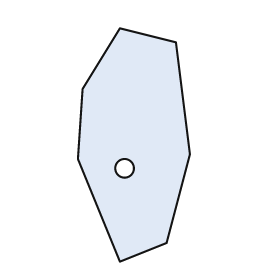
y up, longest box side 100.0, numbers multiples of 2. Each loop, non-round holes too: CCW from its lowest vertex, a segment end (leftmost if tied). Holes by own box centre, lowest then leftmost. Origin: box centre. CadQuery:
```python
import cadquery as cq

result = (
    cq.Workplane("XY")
    .moveTo(-6.0, -50.0)
    .lineTo(14.0, -42.0)
    .lineTo(24.0, -4.0)
    .lineTo(18.0, 44.0)
    .lineTo(-6.0, 50.0)
    .lineTo(-22.0, 24.0)
    .lineTo(-24.0, -6.0)
    .close()
    .moveTo(-4.0, -10.0)
    .circle(4.0)
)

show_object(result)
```